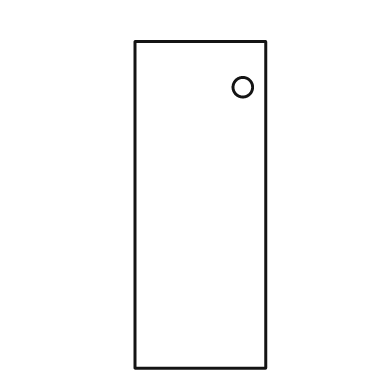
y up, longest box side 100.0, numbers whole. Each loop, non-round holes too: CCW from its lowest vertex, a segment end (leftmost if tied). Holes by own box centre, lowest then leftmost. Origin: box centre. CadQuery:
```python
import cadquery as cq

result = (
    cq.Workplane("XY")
    .moveTo(-20.0, -50.0)
    .lineTo(20.0, -50.0)
    .lineTo(20.0, 50.0)
    .lineTo(-20.0, 50.0)
    .close()
    .moveTo(13.0, 36.0)
    .circle(3.0)
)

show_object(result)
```